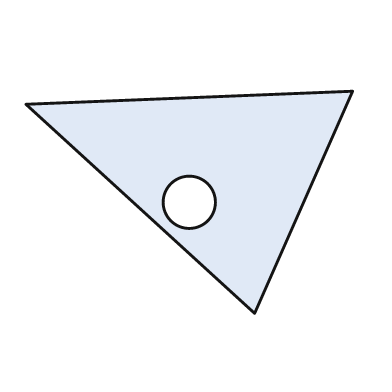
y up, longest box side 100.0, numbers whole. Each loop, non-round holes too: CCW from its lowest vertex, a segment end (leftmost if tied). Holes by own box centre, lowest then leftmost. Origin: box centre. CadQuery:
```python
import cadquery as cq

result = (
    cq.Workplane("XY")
    .moveTo(20.0, -34.0)
    .lineTo(50.0, 34.0)
    .lineTo(-50.0, 30.0)
    .close()
    .moveTo(0.0, 0.0)
    .circle(8.0)
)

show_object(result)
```